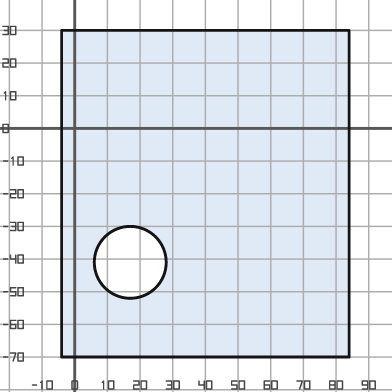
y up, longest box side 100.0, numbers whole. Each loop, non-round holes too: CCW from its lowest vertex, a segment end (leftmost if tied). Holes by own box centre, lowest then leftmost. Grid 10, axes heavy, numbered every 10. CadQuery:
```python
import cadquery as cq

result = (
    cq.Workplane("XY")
    .moveTo(-4.0, -70.0)
    .lineTo(84.0, -70.0)
    .lineTo(84.0, 30.0)
    .lineTo(-4.0, 30.0)
    .close()
    .moveTo(17.0, -41.0)
    .circle(11.0)
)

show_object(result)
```